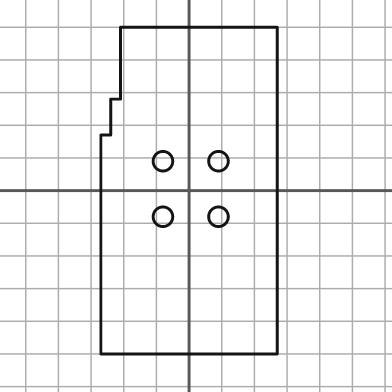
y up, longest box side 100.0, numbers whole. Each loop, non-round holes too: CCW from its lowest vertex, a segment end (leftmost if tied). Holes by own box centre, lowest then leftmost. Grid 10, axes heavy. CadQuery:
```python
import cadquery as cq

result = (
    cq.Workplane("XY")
    .moveTo(-27.0, -50.0)
    .lineTo(27.0, -50.0)
    .lineTo(27.0, 50.0)
    .lineTo(-21.0, 50.0)
    .lineTo(-21.0, 28.0)
    .lineTo(-24.0, 28.0)
    .lineTo(-24.0, 17.0)
    .lineTo(-27.0, 17.0)
    .close()
    .moveTo(-8.0, -8.0)
    .circle(3.0)
    .moveTo(9.0, -8.0)
    .circle(3.0)
    .moveTo(-8.0, 9.0)
    .circle(3.0)
    .moveTo(9.0, 9.0)
    .circle(3.0)
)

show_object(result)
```